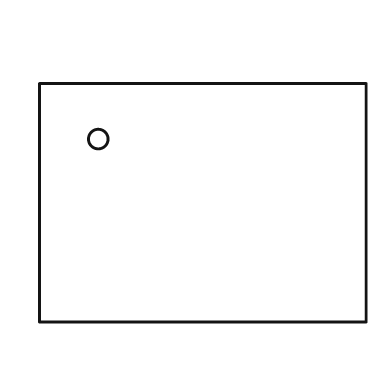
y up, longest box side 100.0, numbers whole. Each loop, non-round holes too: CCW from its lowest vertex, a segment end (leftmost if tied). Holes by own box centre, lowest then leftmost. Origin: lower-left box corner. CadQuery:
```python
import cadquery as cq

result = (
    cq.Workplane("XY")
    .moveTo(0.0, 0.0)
    .lineTo(100.0, 0.0)
    .lineTo(100.0, 73.0)
    .lineTo(0.0, 73.0)
    .close()
    .moveTo(18.0, 56.0)
    .circle(3.0)
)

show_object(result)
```